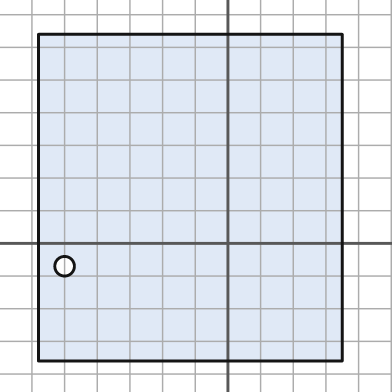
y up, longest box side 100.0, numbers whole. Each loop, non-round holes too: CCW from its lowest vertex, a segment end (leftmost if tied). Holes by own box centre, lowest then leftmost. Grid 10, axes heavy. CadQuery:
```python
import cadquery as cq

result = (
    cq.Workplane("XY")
    .moveTo(-58.0, -36.0)
    .lineTo(35.0, -36.0)
    .lineTo(35.0, 64.0)
    .lineTo(-58.0, 64.0)
    .close()
    .moveTo(-50.0, -7.0)
    .circle(3.0)
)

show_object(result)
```